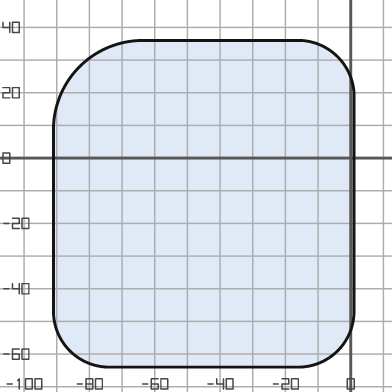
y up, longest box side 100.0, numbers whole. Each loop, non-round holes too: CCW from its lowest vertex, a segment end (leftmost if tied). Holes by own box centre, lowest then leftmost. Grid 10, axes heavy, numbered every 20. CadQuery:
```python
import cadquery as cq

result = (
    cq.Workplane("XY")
    .moveTo(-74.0, -64.0)
    .lineTo(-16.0, -64.0)
    .threePointArc((-4.0, -59.0), (1.0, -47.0))
    .lineTo(1.0, 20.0)
    .threePointArc((-4.0, 31.0), (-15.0, 36.0))
    .lineTo(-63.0, 36.0)
    .threePointArc((-83.0, 28.0), (-91.0, 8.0))
    .lineTo(-91.0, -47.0)
    .threePointArc((-86.0, -59.0), (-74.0, -64.0))
    .close()
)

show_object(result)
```